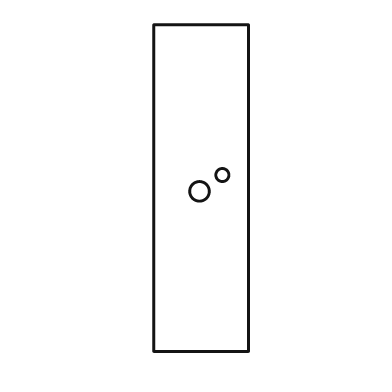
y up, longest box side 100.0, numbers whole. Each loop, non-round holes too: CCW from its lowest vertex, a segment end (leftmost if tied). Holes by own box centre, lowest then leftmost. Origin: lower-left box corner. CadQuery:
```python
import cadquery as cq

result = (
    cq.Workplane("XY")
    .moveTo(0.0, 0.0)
    .lineTo(29.0, 0.0)
    .lineTo(29.0, 100.0)
    .lineTo(0.0, 100.0)
    .close()
    .moveTo(14.0, 49.0)
    .circle(3.0)
    .moveTo(21.0, 54.0)
    .circle(2.0)
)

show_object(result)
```